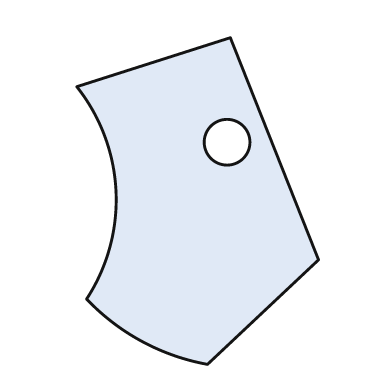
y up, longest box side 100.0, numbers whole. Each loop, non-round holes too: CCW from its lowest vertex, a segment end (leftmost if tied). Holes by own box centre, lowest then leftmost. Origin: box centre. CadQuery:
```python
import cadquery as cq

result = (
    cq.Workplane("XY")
    .moveTo(3.0, -50.0)
    .lineTo(37.0, -18.0)
    .lineTo(10.0, 50.0)
    .lineTo(-37.0, 35.0)
    .threePointArc((-25.0, 3.0), (-34.0, -30.0))
    .threePointArc((-17.0, -43.0), (3.0, -50.0))
    .close()
    .moveTo(9.0, 18.0)
    .circle(7.0)
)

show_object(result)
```